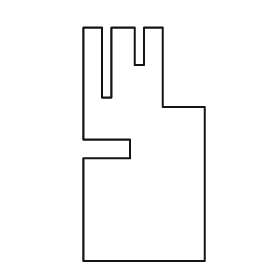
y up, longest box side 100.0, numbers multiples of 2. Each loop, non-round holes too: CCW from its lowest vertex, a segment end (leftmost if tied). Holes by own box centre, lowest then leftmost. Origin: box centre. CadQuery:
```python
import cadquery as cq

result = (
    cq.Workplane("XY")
    .moveTo(-26.0, -50.0)
    .lineTo(26.0, -50.0)
    .lineTo(26.0, 16.0)
    .lineTo(8.0, 16.0)
    .lineTo(8.0, 50.0)
    .lineTo(0.0, 50.0)
    .lineTo(0.0, 34.0)
    .lineTo(-4.0, 34.0)
    .lineTo(-4.0, 50.0)
    .lineTo(-14.0, 50.0)
    .lineTo(-14.0, 20.0)
    .lineTo(-18.0, 20.0)
    .lineTo(-18.0, 50.0)
    .lineTo(-26.0, 50.0)
    .lineTo(-26.0, 2.0)
    .lineTo(-6.0, 2.0)
    .lineTo(-6.0, -6.0)
    .lineTo(-26.0, -6.0)
    .close()
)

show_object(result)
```